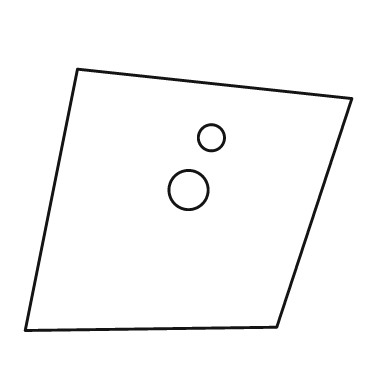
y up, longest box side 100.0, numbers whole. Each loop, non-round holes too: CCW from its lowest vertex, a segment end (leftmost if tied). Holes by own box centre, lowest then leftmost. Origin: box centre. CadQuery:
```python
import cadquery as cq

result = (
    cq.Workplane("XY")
    .moveTo(-50.0, -40.0)
    .lineTo(27.0, -39.0)
    .lineTo(50.0, 31.0)
    .lineTo(-34.0, 40.0)
    .close()
    .moveTo(0.0, 3.0)
    .circle(6.0)
    .moveTo(7.0, 19.0)
    .circle(4.0)
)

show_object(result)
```